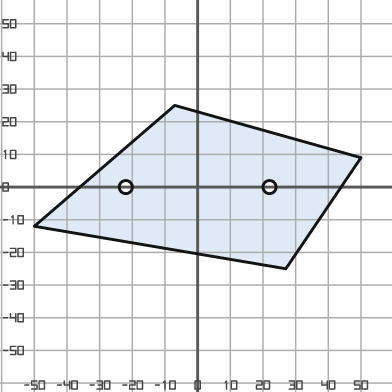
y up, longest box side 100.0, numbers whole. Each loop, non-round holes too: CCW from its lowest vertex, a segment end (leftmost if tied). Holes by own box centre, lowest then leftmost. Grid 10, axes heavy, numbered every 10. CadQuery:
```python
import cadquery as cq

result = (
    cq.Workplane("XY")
    .moveTo(27.0, -25.0)
    .lineTo(50.0, 9.0)
    .lineTo(-7.0, 25.0)
    .lineTo(-50.0, -12.0)
    .close()
    .moveTo(-22.0, 0.0)
    .circle(2.0)
    .moveTo(22.0, 0.0)
    .circle(2.0)
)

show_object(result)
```